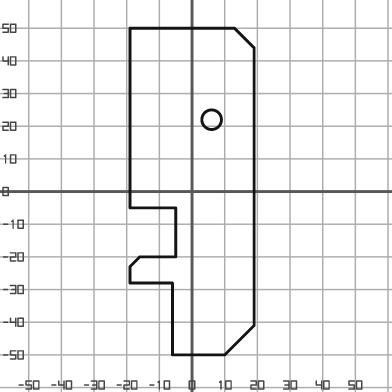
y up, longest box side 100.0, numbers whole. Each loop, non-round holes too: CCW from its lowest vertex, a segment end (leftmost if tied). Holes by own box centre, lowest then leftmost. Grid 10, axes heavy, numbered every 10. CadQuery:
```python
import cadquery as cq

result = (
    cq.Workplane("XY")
    .moveTo(-6.0, -50.0)
    .lineTo(10.0, -50.0)
    .lineTo(19.0, -41.0)
    .lineTo(19.0, 44.0)
    .lineTo(13.0, 50.0)
    .lineTo(-19.0, 50.0)
    .lineTo(-19.0, -5.0)
    .lineTo(-5.0, -5.0)
    .lineTo(-5.0, -20.0)
    .lineTo(-16.0, -20.0)
    .lineTo(-19.0, -23.0)
    .lineTo(-19.0, -28.0)
    .lineTo(-6.0, -28.0)
    .close()
    .moveTo(6.0, 22.0)
    .circle(3.0)
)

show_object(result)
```